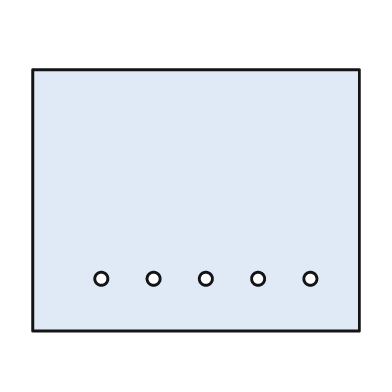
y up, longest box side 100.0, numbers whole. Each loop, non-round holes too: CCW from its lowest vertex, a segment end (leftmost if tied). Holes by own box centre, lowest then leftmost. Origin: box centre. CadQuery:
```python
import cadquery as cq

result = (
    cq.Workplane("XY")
    .moveTo(-50.0, -40.0)
    .lineTo(50.0, -40.0)
    .lineTo(50.0, 40.0)
    .lineTo(-50.0, 40.0)
    .close()
    .moveTo(-29.0, -24.0)
    .circle(2.0)
    .moveTo(-13.0, -24.0)
    .circle(2.0)
    .moveTo(3.0, -24.0)
    .circle(2.0)
    .moveTo(19.0, -24.0)
    .circle(2.0)
    .moveTo(35.0, -24.0)
    .circle(2.0)
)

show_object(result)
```